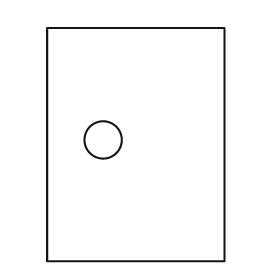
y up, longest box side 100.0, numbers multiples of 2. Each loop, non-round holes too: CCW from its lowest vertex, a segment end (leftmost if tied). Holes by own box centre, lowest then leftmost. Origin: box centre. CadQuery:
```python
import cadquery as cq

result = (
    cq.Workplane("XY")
    .moveTo(-38.0, -50.0)
    .lineTo(38.0, -50.0)
    .lineTo(38.0, 50.0)
    .lineTo(-38.0, 50.0)
    .close()
    .moveTo(-14.0, 2.0)
    .circle(8.0)
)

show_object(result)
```